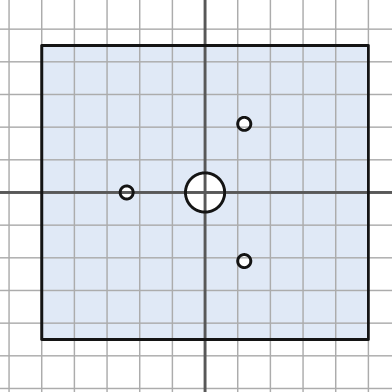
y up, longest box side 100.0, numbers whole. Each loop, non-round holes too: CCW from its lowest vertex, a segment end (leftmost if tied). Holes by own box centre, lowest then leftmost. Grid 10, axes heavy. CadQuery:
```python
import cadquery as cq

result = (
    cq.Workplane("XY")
    .moveTo(-50.0, -45.0)
    .lineTo(50.0, -45.0)
    .lineTo(50.0, 45.0)
    .lineTo(-50.0, 45.0)
    .close()
    .moveTo(12.0, -21.0)
    .circle(2.0)
    .moveTo(-24.0, 0.0)
    .circle(2.0)
    .moveTo(0.0, 0.0)
    .circle(6.0)
    .moveTo(12.0, 21.0)
    .circle(2.0)
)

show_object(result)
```